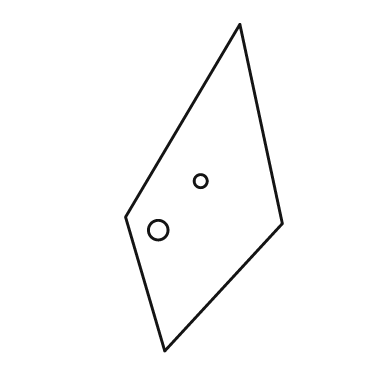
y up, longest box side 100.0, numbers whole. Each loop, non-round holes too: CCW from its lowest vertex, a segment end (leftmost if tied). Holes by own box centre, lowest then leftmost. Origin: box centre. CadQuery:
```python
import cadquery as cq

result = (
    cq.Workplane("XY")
    .moveTo(-12.0, -50.0)
    .lineTo(24.0, -11.0)
    .lineTo(11.0, 50.0)
    .lineTo(-24.0, -9.0)
    .close()
    .moveTo(-14.0, -13.0)
    .circle(3.0)
    .moveTo(-1.0, 2.0)
    .circle(2.0)
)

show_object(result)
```